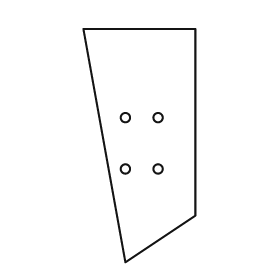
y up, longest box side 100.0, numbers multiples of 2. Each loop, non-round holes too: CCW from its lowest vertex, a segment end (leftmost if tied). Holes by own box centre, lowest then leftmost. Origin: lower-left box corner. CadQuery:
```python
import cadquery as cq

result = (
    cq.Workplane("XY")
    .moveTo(18.0, 0.0)
    .lineTo(48.0, 20.0)
    .lineTo(48.0, 100.0)
    .lineTo(0.0, 100.0)
    .close()
    .moveTo(18.0, 40.0)
    .circle(2.0)
    .moveTo(32.0, 40.0)
    .circle(2.0)
    .moveTo(18.0, 62.0)
    .circle(2.0)
    .moveTo(32.0, 62.0)
    .circle(2.0)
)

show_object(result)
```